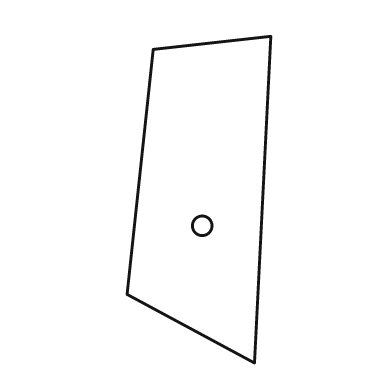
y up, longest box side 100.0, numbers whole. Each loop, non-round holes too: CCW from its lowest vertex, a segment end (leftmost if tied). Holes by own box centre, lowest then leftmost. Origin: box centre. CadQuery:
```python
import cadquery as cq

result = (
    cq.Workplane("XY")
    .moveTo(17.0, -50.0)
    .lineTo(22.0, 50.0)
    .lineTo(-14.0, 46.0)
    .lineTo(-22.0, -29.0)
    .close()
    .moveTo(1.0, -8.0)
    .circle(3.0)
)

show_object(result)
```